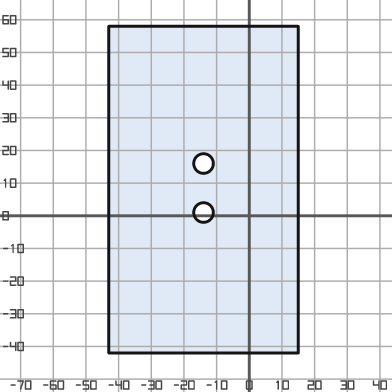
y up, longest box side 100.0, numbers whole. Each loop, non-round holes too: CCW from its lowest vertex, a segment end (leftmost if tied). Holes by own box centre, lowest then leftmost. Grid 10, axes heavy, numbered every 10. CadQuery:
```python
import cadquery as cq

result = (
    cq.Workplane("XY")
    .moveTo(-43.0, -42.0)
    .lineTo(15.0, -42.0)
    .lineTo(15.0, 58.0)
    .lineTo(-43.0, 58.0)
    .close()
    .moveTo(-14.0, 1.0)
    .circle(3.0)
    .moveTo(-14.0, 16.0)
    .circle(3.0)
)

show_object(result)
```